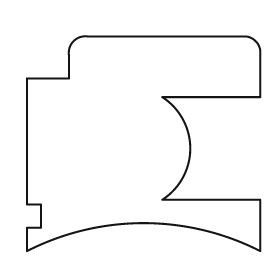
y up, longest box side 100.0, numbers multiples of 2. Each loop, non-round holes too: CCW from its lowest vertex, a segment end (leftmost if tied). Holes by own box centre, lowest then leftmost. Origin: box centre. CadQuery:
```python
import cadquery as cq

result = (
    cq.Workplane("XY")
    .moveTo(-50.0, -46.0)
    .threePointArc((0.0, -34.0), (50.0, -46.0))
    .lineTo(50.0, -24.0)
    .lineTo(8.0, -24.0)
    .threePointArc((20.0, -2.0), (8.0, 20.0))
    .lineTo(50.0, 20.0)
    .lineTo(50.0, 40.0)
    .threePointArc((48.0, 44.0), (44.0, 46.0))
    .lineTo(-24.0, 46.0)
    .threePointArc((-30.0, 44.0), (-32.0, 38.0))
    .lineTo(-32.0, 28.0)
    .lineTo(-50.0, 28.0)
    .lineTo(-50.0, -26.0)
    .lineTo(-44.0, -26.0)
    .lineTo(-44.0, -36.0)
    .lineTo(-50.0, -36.0)
    .close()
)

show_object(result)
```